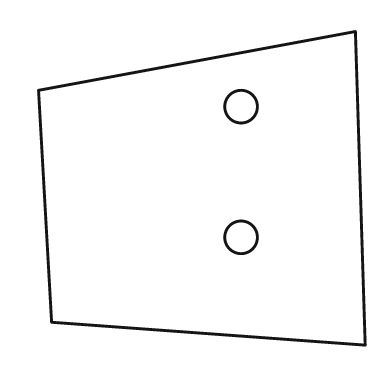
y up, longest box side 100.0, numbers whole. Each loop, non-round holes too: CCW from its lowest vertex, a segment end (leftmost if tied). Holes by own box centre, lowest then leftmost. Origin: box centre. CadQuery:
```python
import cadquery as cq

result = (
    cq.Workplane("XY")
    .moveTo(50.0, -48.0)
    .lineTo(47.0, 48.0)
    .lineTo(-50.0, 30.0)
    .lineTo(-46.0, -41.0)
    .close()
    .moveTo(12.0, -15.0)
    .circle(5.0)
    .moveTo(12.0, 25.0)
    .circle(5.0)
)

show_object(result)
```